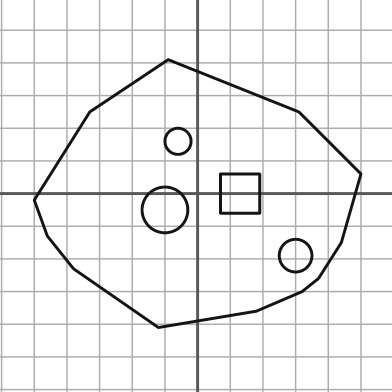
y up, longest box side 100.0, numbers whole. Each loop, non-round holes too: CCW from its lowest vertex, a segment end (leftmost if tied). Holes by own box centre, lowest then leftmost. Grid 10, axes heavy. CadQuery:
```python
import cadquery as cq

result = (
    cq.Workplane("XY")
    .moveTo(-12.0, -41.0)
    .lineTo(18.0, -36.0)
    .lineTo(32.0, -30.0)
    .lineTo(37.0, -26.0)
    .lineTo(44.0, -15.0)
    .lineTo(50.0, 6.0)
    .lineTo(31.0, 25.0)
    .lineTo(-9.0, 41.0)
    .lineTo(-33.0, 25.0)
    .lineTo(-50.0, -2.0)
    .lineTo(-46.0, -13.0)
    .lineTo(-38.0, -23.0)
    .close()
    .moveTo(30.0, -19.0)
    .circle(5.0)
    .moveTo(-10.0, -5.0)
    .circle(7.0)
    .moveTo(7.0, -6.0)
    .lineTo(19.0, -6.0)
    .lineTo(19.0, 6.0)
    .lineTo(7.0, 6.0)
    .close()
    .moveTo(-6.0, 16.0)
    .circle(4.0)
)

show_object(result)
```